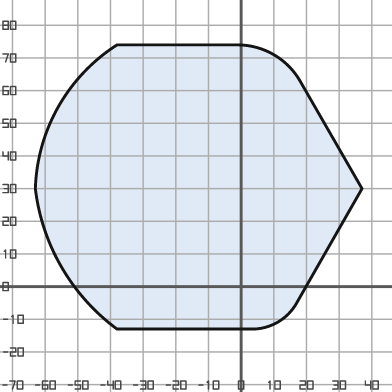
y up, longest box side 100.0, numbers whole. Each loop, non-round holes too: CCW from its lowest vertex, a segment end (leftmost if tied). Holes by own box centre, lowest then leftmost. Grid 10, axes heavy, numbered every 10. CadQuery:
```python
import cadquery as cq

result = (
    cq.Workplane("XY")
    .moveTo(-38.0, -13.0)
    .lineTo(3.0, -13.0)
    .threePointArc((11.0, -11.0), (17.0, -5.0))
    .lineTo(37.0, 30.0)
    .lineTo(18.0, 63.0)
    .threePointArc((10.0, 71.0), (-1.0, 74.0))
    .lineTo(-38.0, 74.0)
    .threePointArc((-56.0, 55.0), (-63.0, 30.0))
    .threePointArc((-55.0, 6.0), (-38.0, -13.0))
    .close()
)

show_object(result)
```